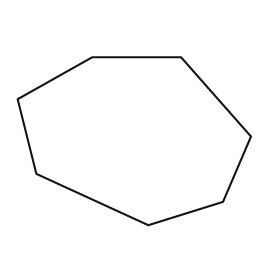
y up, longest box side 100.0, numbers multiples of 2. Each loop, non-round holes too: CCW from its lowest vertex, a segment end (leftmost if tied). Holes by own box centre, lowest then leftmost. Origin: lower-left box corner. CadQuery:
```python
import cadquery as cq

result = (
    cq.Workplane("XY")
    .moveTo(56.0, 0.0)
    .lineTo(88.0, 10.0)
    .lineTo(100.0, 38.0)
    .lineTo(70.0, 72.0)
    .lineTo(32.0, 72.0)
    .lineTo(0.0, 54.0)
    .lineTo(8.0, 22.0)
    .close()
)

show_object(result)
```